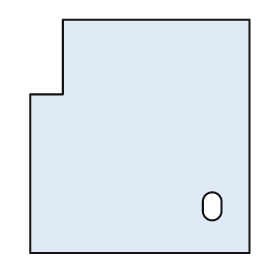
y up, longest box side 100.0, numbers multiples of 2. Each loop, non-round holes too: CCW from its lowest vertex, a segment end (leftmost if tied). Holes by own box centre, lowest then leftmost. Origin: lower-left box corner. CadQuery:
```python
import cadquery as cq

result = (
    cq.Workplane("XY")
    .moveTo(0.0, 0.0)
    .lineTo(94.0, 0.0)
    .lineTo(94.0, 100.0)
    .lineTo(14.0, 100.0)
    .lineTo(14.0, 68.0)
    .lineTo(0.0, 68.0)
    .close()
    .moveTo(74.0, 18.0)
    .threePointArc((78.0, 14.0), (82.0, 18.0))
    .lineTo(82.0, 22.0)
    .threePointArc((78.0, 26.0), (74.0, 22.0))
    .close()
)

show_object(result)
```